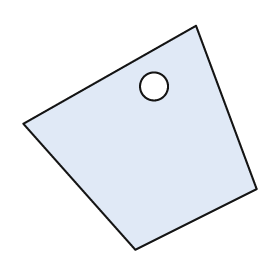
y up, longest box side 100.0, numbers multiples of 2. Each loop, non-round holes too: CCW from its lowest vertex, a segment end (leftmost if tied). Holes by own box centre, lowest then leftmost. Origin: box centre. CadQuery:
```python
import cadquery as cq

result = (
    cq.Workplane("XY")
    .moveTo(-2.0, -48.0)
    .lineTo(50.0, -22.0)
    .lineTo(24.0, 48.0)
    .lineTo(-50.0, 6.0)
    .close()
    .moveTo(6.0, 22.0)
    .circle(6.0)
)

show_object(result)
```